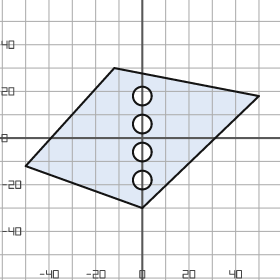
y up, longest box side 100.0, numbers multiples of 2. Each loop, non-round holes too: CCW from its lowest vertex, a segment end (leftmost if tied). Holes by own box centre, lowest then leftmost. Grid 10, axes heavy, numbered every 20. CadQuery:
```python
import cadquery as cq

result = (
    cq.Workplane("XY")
    .moveTo(0.0, -30.0)
    .lineTo(50.0, 18.0)
    .lineTo(-12.0, 30.0)
    .lineTo(-50.0, -12.0)
    .close()
    .moveTo(0.0, -18.0)
    .circle(4.0)
    .moveTo(0.0, -6.0)
    .circle(4.0)
    .moveTo(0.0, 6.0)
    .circle(4.0)
    .moveTo(0.0, 18.0)
    .circle(4.0)
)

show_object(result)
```